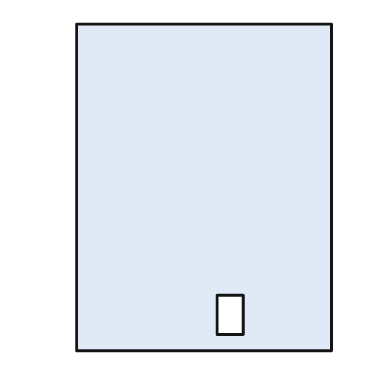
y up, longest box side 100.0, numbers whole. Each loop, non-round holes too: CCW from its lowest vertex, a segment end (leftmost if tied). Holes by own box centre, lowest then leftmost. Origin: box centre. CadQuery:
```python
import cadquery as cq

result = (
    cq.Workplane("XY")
    .moveTo(-39.0, -50.0)
    .lineTo(39.0, -50.0)
    .lineTo(39.0, 50.0)
    .lineTo(-39.0, 50.0)
    .close()
    .moveTo(4.0, -45.0)
    .lineTo(12.0, -45.0)
    .lineTo(12.0, -33.0)
    .lineTo(4.0, -33.0)
    .close()
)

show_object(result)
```